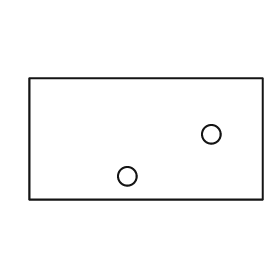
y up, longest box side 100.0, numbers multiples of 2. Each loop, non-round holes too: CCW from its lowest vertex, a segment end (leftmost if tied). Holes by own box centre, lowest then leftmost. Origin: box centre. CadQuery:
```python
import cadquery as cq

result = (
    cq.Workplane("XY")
    .moveTo(-50.0, -26.0)
    .lineTo(50.0, -26.0)
    .lineTo(50.0, 26.0)
    .lineTo(-50.0, 26.0)
    .close()
    .moveTo(-8.0, -16.0)
    .circle(4.0)
    .moveTo(28.0, 2.0)
    .circle(4.0)
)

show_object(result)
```